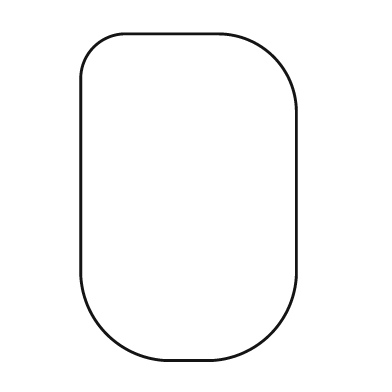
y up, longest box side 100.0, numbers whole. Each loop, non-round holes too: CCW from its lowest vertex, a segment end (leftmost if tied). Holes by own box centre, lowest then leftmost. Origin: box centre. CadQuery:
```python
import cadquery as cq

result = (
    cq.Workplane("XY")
    .moveTo(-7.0, -50.0)
    .lineTo(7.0, -50.0)
    .threePointArc((25.0, -42.0), (33.0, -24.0))
    .lineTo(33.0, 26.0)
    .threePointArc((26.0, 43.0), (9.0, 50.0))
    .lineTo(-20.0, 50.0)
    .threePointArc((-29.0, 46.0), (-33.0, 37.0))
    .lineTo(-33.0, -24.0)
    .threePointArc((-25.0, -42.0), (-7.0, -50.0))
    .close()
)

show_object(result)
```